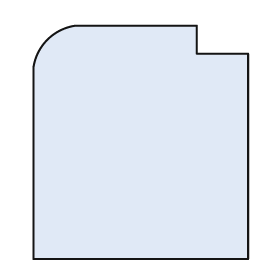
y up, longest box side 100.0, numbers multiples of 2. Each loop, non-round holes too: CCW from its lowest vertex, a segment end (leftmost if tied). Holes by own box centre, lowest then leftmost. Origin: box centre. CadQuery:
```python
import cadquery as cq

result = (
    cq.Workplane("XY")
    .moveTo(-46.0, -50.0)
    .lineTo(46.0, -50.0)
    .lineTo(46.0, 38.0)
    .lineTo(24.0, 38.0)
    .lineTo(24.0, 50.0)
    .lineTo(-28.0, 50.0)
    .threePointArc((-40.0, 44.0), (-46.0, 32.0))
    .close()
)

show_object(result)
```